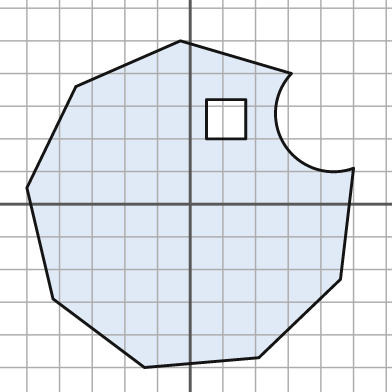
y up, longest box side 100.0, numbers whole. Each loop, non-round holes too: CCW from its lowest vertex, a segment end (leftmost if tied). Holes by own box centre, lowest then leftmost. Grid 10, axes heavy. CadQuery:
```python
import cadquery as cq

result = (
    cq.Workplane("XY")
    .moveTo(-14.0, -50.0)
    .lineTo(21.0, -47.0)
    .lineTo(46.0, -23.0)
    .lineTo(50.0, 11.0)
    .threePointArc((29.0, 18.0), (31.0, 40.0))
    .lineTo(-3.0, 50.0)
    .lineTo(-35.0, 36.0)
    .lineTo(-50.0, 5.0)
    .lineTo(-42.0, -29.0)
    .close()
    .moveTo(5.0, 20.0)
    .lineTo(17.0, 20.0)
    .lineTo(17.0, 32.0)
    .lineTo(5.0, 32.0)
    .close()
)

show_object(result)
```